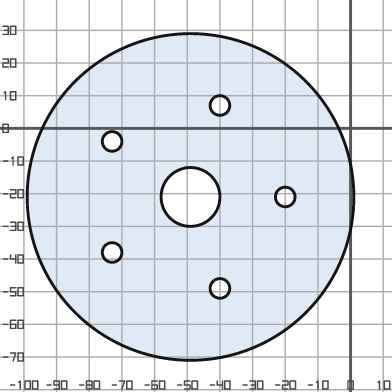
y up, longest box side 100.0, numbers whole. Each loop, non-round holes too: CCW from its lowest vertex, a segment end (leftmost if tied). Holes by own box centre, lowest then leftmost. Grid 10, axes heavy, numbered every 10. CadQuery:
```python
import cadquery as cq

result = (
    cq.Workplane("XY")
    .moveTo(-49.0, -21.0)
    .circle(50.0)
    .moveTo(-40.0, -49.0)
    .circle(3.0)
    .moveTo(-73.0, -38.0)
    .circle(3.0)
    .moveTo(-49.0, -21.0)
    .circle(9.0)
    .moveTo(-20.0, -21.0)
    .circle(3.0)
    .moveTo(-73.0, -4.0)
    .circle(3.0)
    .moveTo(-40.0, 7.0)
    .circle(3.0)
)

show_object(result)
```